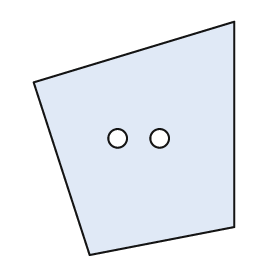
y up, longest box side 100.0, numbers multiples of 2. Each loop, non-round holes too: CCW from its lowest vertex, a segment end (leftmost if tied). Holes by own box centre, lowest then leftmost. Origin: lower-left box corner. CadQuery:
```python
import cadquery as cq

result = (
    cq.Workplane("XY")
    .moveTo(24.0, 0.0)
    .lineTo(86.0, 12.0)
    .lineTo(86.0, 100.0)
    .lineTo(0.0, 74.0)
    .close()
    .moveTo(36.0, 50.0)
    .circle(4.0)
    .moveTo(54.0, 50.0)
    .circle(4.0)
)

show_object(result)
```